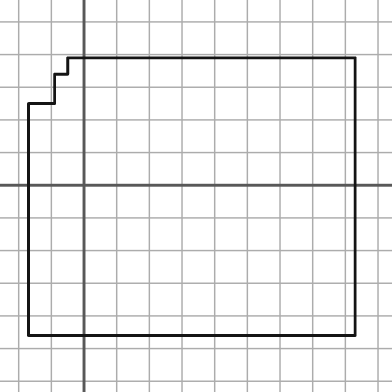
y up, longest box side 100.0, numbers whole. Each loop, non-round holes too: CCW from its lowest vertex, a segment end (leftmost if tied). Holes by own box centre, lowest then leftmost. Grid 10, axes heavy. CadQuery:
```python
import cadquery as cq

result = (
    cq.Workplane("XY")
    .moveTo(-17.0, -46.0)
    .lineTo(83.0, -46.0)
    .lineTo(83.0, 39.0)
    .lineTo(-5.0, 39.0)
    .lineTo(-5.0, 34.0)
    .lineTo(-9.0, 34.0)
    .lineTo(-9.0, 25.0)
    .lineTo(-17.0, 25.0)
    .close()
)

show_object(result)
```